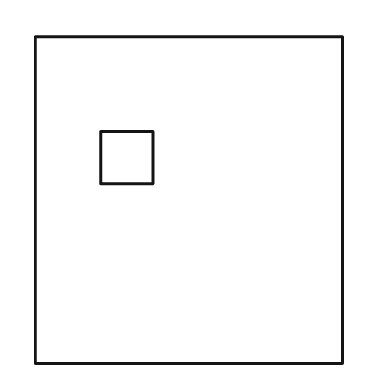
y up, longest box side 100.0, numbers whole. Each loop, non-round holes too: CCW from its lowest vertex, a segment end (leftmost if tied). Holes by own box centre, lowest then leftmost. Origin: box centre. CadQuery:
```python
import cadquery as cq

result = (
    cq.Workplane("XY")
    .moveTo(-47.0, -50.0)
    .lineTo(47.0, -50.0)
    .lineTo(47.0, 50.0)
    .lineTo(-47.0, 50.0)
    .close()
    .moveTo(-27.0, 5.0)
    .lineTo(-11.0, 5.0)
    .lineTo(-11.0, 21.0)
    .lineTo(-27.0, 21.0)
    .close()
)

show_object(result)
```